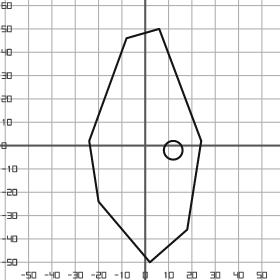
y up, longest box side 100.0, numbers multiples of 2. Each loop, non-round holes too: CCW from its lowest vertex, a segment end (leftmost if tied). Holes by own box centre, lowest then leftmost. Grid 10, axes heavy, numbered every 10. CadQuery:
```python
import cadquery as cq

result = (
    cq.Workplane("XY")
    .moveTo(2.0, -50.0)
    .lineTo(18.0, -36.0)
    .lineTo(24.0, 2.0)
    .lineTo(6.0, 50.0)
    .lineTo(-8.0, 46.0)
    .lineTo(-24.0, 2.0)
    .lineTo(-20.0, -24.0)
    .close()
    .moveTo(12.0, -2.0)
    .circle(4.0)
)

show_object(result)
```